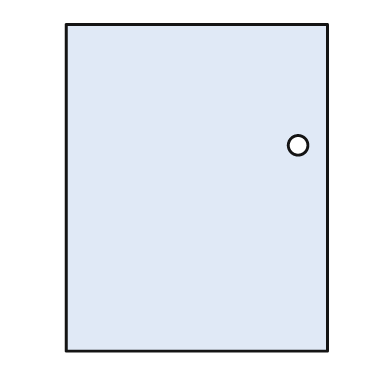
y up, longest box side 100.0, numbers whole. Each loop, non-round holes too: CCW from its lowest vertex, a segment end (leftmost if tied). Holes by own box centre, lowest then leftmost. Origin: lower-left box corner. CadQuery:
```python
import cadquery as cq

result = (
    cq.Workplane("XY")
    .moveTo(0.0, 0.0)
    .lineTo(80.0, 0.0)
    .lineTo(80.0, 100.0)
    .lineTo(0.0, 100.0)
    .close()
    .moveTo(71.0, 63.0)
    .circle(3.0)
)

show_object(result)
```